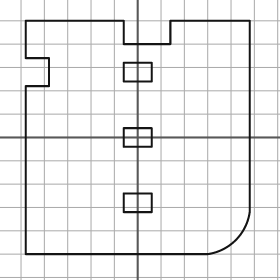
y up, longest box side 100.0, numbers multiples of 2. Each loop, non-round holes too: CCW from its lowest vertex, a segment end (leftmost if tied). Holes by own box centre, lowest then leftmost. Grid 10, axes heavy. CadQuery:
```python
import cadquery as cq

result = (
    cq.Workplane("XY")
    .moveTo(-48.0, -50.0)
    .lineTo(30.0, -50.0)
    .threePointArc((42.0, -44.0), (48.0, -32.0))
    .lineTo(48.0, 50.0)
    .lineTo(14.0, 50.0)
    .lineTo(14.0, 40.0)
    .lineTo(-6.0, 40.0)
    .lineTo(-6.0, 50.0)
    .lineTo(-48.0, 50.0)
    .lineTo(-48.0, 34.0)
    .lineTo(-38.0, 34.0)
    .lineTo(-38.0, 22.0)
    .lineTo(-48.0, 22.0)
    .close()
    .moveTo(-6.0, -32.0)
    .lineTo(6.0, -32.0)
    .lineTo(6.0, -24.0)
    .lineTo(-6.0, -24.0)
    .close()
    .moveTo(-6.0, -4.0)
    .lineTo(6.0, -4.0)
    .lineTo(6.0, 4.0)
    .lineTo(-6.0, 4.0)
    .close()
    .moveTo(-6.0, 24.0)
    .lineTo(6.0, 24.0)
    .lineTo(6.0, 32.0)
    .lineTo(-6.0, 32.0)
    .close()
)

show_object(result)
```